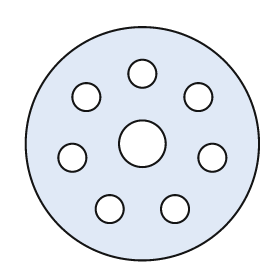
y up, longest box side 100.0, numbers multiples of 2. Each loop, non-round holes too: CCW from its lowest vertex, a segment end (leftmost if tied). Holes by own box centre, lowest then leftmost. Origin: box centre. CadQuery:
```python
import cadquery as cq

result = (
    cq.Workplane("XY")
    .moveTo(0.0, 0.0)
    .circle(50.0)
    .moveTo(-14.0, -28.0)
    .circle(6.0)
    .moveTo(14.0, -28.0)
    .circle(6.0)
    .moveTo(-30.0, -6.0)
    .circle(6.0)
    .moveTo(30.0, -6.0)
    .circle(6.0)
    .moveTo(0.0, 0.0)
    .circle(10.0)
    .moveTo(-24.0, 20.0)
    .circle(6.0)
    .moveTo(24.0, 20.0)
    .circle(6.0)
    .moveTo(0.0, 30.0)
    .circle(6.0)
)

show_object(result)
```